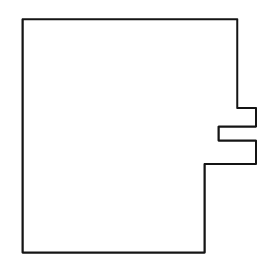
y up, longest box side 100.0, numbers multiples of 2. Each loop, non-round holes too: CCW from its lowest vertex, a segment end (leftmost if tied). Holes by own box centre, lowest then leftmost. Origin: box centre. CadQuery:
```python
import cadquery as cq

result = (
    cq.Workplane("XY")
    .moveTo(-50.0, -50.0)
    .lineTo(28.0, -50.0)
    .lineTo(28.0, -12.0)
    .lineTo(50.0, -12.0)
    .lineTo(50.0, -2.0)
    .lineTo(34.0, -2.0)
    .lineTo(34.0, 4.0)
    .lineTo(50.0, 4.0)
    .lineTo(50.0, 12.0)
    .lineTo(42.0, 12.0)
    .lineTo(42.0, 50.0)
    .lineTo(-50.0, 50.0)
    .close()
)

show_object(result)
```